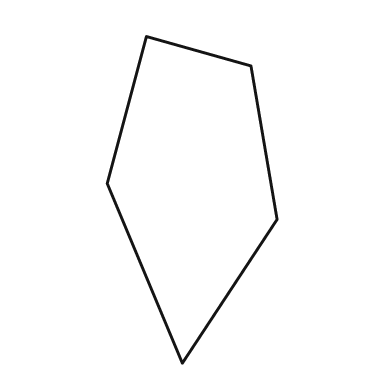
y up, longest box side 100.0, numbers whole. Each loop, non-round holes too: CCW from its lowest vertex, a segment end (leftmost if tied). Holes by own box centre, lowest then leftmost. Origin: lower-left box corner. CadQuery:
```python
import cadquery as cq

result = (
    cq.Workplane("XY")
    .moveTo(23.0, 0.0)
    .lineTo(52.0, 44.0)
    .lineTo(44.0, 91.0)
    .lineTo(12.0, 100.0)
    .lineTo(0.0, 55.0)
    .close()
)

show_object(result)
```